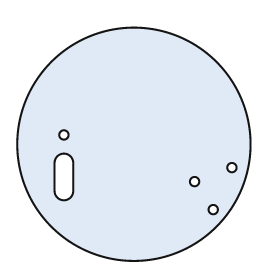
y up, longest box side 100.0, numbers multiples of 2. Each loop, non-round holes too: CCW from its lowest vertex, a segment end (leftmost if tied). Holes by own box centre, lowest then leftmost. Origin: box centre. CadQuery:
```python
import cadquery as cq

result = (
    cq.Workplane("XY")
    .moveTo(0.0, 0.0)
    .circle(50.0)
    .moveTo(34.0, -28.0)
    .circle(2.0)
    .moveTo(26.0, -16.0)
    .circle(2.0)
    .moveTo(-34.0, -20.0)
    .threePointArc((-30.0, -24.0), (-26.0, -20.0))
    .lineTo(-26.0, -8.0)
    .threePointArc((-30.0, -4.0), (-34.0, -8.0))
    .close()
    .moveTo(42.0, -10.0)
    .circle(2.0)
    .moveTo(-30.0, 4.0)
    .circle(2.0)
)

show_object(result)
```